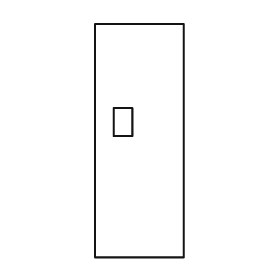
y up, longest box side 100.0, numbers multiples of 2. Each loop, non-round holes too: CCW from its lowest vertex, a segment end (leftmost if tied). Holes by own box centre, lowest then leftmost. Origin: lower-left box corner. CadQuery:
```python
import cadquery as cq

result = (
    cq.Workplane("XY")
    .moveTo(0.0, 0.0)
    .lineTo(38.0, 0.0)
    .lineTo(38.0, 100.0)
    .lineTo(0.0, 100.0)
    .close()
    .moveTo(8.0, 52.0)
    .lineTo(16.0, 52.0)
    .lineTo(16.0, 64.0)
    .lineTo(8.0, 64.0)
    .close()
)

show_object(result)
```